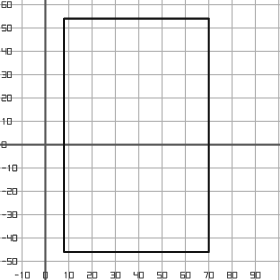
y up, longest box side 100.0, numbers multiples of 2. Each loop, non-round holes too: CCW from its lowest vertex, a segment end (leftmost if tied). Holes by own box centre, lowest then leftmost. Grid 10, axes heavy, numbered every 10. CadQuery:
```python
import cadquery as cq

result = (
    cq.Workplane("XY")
    .moveTo(8.0, -46.0)
    .lineTo(70.0, -46.0)
    .lineTo(70.0, 54.0)
    .lineTo(8.0, 54.0)
    .close()
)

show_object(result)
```